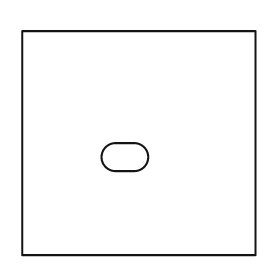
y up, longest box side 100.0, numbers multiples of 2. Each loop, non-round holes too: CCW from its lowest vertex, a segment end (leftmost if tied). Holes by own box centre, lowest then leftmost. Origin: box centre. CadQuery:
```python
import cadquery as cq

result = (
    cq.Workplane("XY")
    .moveTo(-50.0, -48.0)
    .lineTo(50.0, -48.0)
    .lineTo(50.0, 48.0)
    .lineTo(-50.0, 48.0)
    .close()
    .moveTo(-10.0, -12.0)
    .lineTo(-2.0, -12.0)
    .threePointArc((4.0, -6.0), (-2.0, 0.0))
    .lineTo(-10.0, 0.0)
    .threePointArc((-16.0, -6.0), (-10.0, -12.0))
    .close()
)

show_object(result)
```